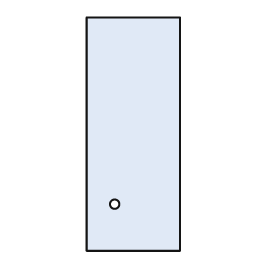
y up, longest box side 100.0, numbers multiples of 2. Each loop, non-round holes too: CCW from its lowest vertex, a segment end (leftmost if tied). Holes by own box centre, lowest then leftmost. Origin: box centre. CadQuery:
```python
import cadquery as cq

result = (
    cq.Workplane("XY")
    .moveTo(-20.0, -50.0)
    .lineTo(20.0, -50.0)
    .lineTo(20.0, 50.0)
    .lineTo(-20.0, 50.0)
    .close()
    .moveTo(-8.0, -30.0)
    .circle(2.0)
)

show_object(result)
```